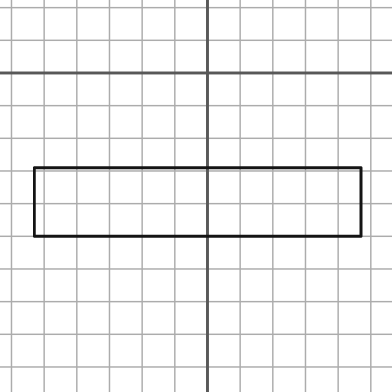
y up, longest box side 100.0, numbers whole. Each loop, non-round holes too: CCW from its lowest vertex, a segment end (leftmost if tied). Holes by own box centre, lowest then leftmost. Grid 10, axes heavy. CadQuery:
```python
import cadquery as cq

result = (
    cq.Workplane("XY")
    .moveTo(-53.0, -50.0)
    .lineTo(47.0, -50.0)
    .lineTo(47.0, -29.0)
    .lineTo(-53.0, -29.0)
    .close()
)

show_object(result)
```